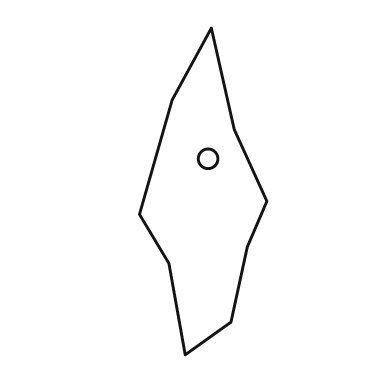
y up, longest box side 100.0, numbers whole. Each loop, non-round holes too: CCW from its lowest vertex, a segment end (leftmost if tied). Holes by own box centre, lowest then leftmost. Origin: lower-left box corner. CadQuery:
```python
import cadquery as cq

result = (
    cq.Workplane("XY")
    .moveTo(14.0, 0.0)
    .lineTo(28.0, 10.0)
    .lineTo(33.0, 33.0)
    .lineTo(39.0, 47.0)
    .lineTo(29.0, 69.0)
    .lineTo(22.0, 100.0)
    .lineTo(10.0, 78.0)
    .lineTo(0.0, 43.0)
    .lineTo(9.0, 28.0)
    .close()
    .moveTo(21.0, 60.0)
    .circle(3.0)
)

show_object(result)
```